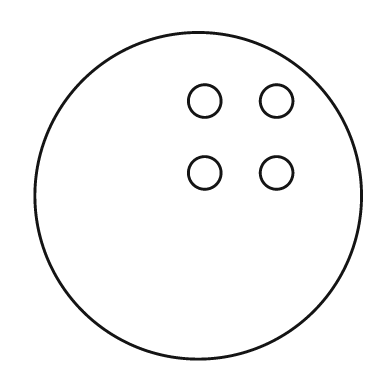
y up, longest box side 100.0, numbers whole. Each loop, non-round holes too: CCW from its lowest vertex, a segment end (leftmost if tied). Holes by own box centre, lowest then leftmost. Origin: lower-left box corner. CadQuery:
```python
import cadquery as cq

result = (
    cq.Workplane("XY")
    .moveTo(50.0, 50.0)
    .circle(50.0)
    .moveTo(52.0, 57.0)
    .circle(5.0)
    .moveTo(74.0, 57.0)
    .circle(5.0)
    .moveTo(52.0, 79.0)
    .circle(5.0)
    .moveTo(74.0, 79.0)
    .circle(5.0)
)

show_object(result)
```